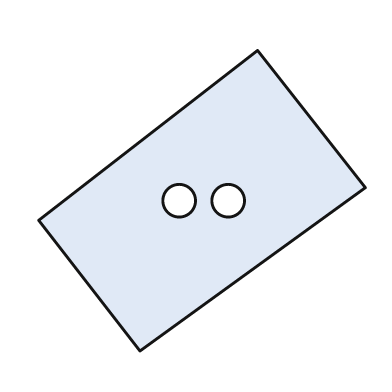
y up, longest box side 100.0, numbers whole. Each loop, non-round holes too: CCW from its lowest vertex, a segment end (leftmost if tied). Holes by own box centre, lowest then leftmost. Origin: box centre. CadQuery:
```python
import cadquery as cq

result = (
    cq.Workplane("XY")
    .moveTo(-19.0, -46.0)
    .lineTo(50.0, 4.0)
    .lineTo(17.0, 46.0)
    .lineTo(-50.0, -6.0)
    .close()
    .moveTo(-7.0, 0.0)
    .circle(5.0)
    .moveTo(8.0, 0.0)
    .circle(5.0)
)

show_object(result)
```